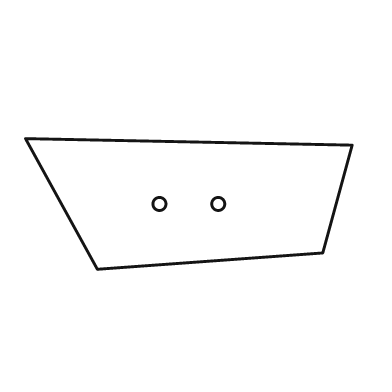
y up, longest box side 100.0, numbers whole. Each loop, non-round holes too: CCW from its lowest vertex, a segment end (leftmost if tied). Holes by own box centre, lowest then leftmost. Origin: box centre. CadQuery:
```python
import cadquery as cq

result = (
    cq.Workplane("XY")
    .moveTo(-28.0, -20.0)
    .lineTo(41.0, -15.0)
    .lineTo(50.0, 18.0)
    .lineTo(-50.0, 20.0)
    .close()
    .moveTo(-9.0, 0.0)
    .circle(2.0)
    .moveTo(9.0, 0.0)
    .circle(2.0)
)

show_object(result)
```